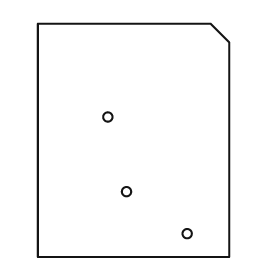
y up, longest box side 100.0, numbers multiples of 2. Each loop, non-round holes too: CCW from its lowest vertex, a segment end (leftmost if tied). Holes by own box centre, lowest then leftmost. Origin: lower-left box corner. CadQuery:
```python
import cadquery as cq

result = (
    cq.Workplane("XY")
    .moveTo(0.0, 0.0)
    .lineTo(82.0, 0.0)
    .lineTo(82.0, 92.0)
    .lineTo(74.0, 100.0)
    .lineTo(0.0, 100.0)
    .close()
    .moveTo(64.0, 10.0)
    .circle(2.0)
    .moveTo(38.0, 28.0)
    .circle(2.0)
    .moveTo(30.0, 60.0)
    .circle(2.0)
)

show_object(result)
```